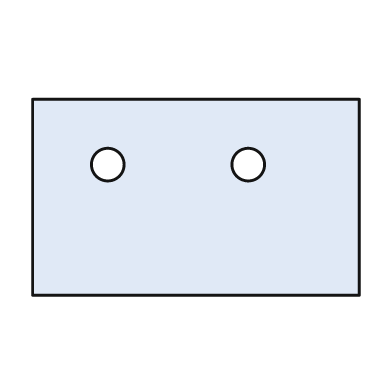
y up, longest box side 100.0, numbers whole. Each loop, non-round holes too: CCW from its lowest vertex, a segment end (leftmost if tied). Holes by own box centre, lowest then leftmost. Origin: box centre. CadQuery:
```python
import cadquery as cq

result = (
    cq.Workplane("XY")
    .moveTo(-50.0, -30.0)
    .lineTo(50.0, -30.0)
    .lineTo(50.0, 30.0)
    .lineTo(-50.0, 30.0)
    .close()
    .moveTo(-27.0, 10.0)
    .circle(5.0)
    .moveTo(16.0, 10.0)
    .circle(5.0)
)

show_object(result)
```